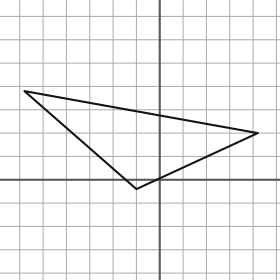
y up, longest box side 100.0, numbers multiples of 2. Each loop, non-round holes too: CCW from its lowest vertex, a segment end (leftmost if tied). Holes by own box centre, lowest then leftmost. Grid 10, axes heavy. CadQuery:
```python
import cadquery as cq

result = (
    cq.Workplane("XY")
    .moveTo(-10.0, -4.0)
    .lineTo(42.0, 20.0)
    .lineTo(-58.0, 38.0)
    .close()
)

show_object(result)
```